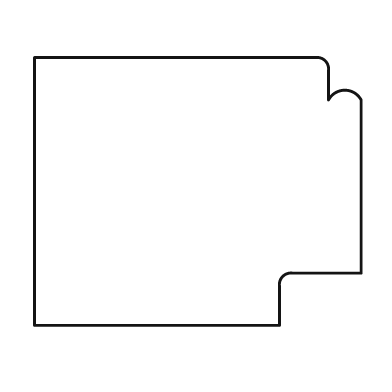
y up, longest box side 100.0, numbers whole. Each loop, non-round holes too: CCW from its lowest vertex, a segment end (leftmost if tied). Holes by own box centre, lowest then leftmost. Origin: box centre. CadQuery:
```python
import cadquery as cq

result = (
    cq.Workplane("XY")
    .moveTo(-50.0, -41.0)
    .lineTo(25.0, -41.0)
    .lineTo(25.0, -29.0)
    .threePointArc((26.0, -26.0), (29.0, -25.0))
    .lineTo(50.0, -25.0)
    .lineTo(50.0, 28.0)
    .threePointArc((45.0, 31.0), (40.0, 28.0))
    .lineTo(40.0, 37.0)
    .threePointArc((39.0, 40.0), (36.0, 41.0))
    .lineTo(-50.0, 41.0)
    .close()
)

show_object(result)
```